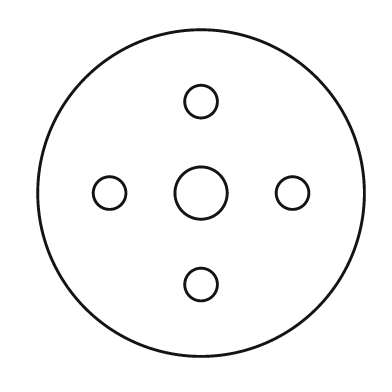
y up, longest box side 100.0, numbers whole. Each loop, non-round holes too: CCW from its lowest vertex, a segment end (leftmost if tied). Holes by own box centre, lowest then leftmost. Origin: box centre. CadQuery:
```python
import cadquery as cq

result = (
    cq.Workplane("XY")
    .moveTo(0.0, 0.0)
    .circle(50.0)
    .moveTo(0.0, -28.0)
    .circle(5.0)
    .moveTo(-28.0, 0.0)
    .circle(5.0)
    .moveTo(0.0, 0.0)
    .circle(8.0)
    .moveTo(28.0, 0.0)
    .circle(5.0)
    .moveTo(0.0, 28.0)
    .circle(5.0)
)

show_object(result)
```